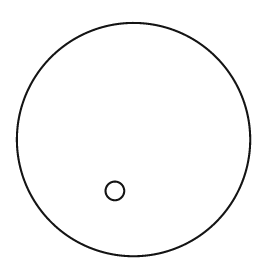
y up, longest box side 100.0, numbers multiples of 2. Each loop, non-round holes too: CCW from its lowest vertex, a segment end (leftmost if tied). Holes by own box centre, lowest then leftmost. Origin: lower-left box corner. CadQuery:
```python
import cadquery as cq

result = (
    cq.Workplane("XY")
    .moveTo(50.0, 50.0)
    .circle(50.0)
    .moveTo(42.0, 28.0)
    .circle(4.0)
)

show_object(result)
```